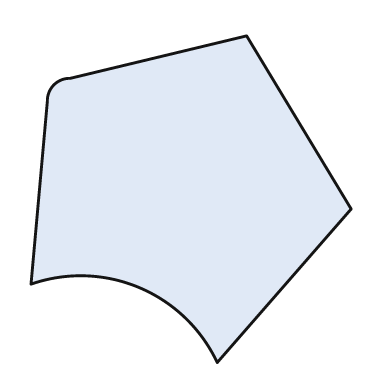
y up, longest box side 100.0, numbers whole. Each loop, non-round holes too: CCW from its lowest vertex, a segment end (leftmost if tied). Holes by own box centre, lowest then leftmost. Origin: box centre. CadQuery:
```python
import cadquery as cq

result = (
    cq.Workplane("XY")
    .moveTo(8.0, -50.0)
    .lineTo(49.0, -3.0)
    .lineTo(17.0, 50.0)
    .lineTo(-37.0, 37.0)
    .threePointArc((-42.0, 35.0), (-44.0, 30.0))
    .lineTo(-49.0, -26.0)
    .threePointArc((-16.0, -27.0), (8.0, -50.0))
    .close()
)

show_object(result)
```